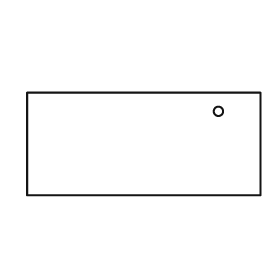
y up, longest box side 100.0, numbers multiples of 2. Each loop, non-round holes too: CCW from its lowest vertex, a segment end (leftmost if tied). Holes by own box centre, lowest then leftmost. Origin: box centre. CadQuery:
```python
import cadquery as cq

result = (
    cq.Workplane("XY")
    .moveTo(-50.0, -22.0)
    .lineTo(50.0, -22.0)
    .lineTo(50.0, 22.0)
    .lineTo(-50.0, 22.0)
    .close()
    .moveTo(32.0, 14.0)
    .circle(2.0)
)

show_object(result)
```